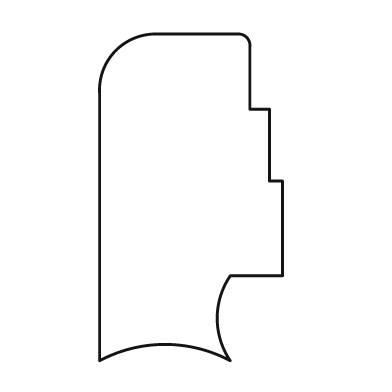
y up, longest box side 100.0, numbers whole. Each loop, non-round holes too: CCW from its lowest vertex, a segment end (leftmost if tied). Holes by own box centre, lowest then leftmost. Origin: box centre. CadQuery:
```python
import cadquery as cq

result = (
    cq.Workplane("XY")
    .moveTo(-28.0, -50.0)
    .threePointArc((-8.0, -45.0), (12.0, -50.0))
    .threePointArc((8.0, -37.0), (12.0, -24.0))
    .lineTo(28.0, -24.0)
    .lineTo(28.0, 5.0)
    .lineTo(24.0, 5.0)
    .lineTo(24.0, 27.0)
    .lineTo(18.0, 27.0)
    .lineTo(18.0, 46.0)
    .threePointArc((17.0, 49.0), (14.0, 50.0))
    .lineTo(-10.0, 50.0)
    .threePointArc((-23.0, 45.0), (-28.0, 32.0))
    .close()
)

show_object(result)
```